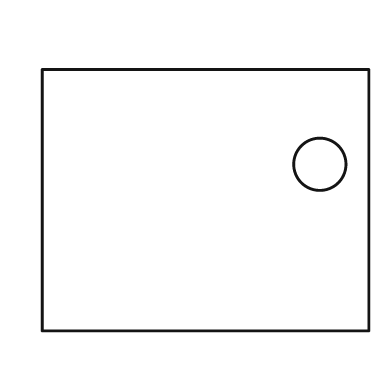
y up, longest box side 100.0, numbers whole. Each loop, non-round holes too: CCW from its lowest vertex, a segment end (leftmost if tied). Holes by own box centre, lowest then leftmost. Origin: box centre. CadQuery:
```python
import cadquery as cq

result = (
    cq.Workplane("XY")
    .moveTo(-50.0, -40.0)
    .lineTo(50.0, -40.0)
    .lineTo(50.0, 40.0)
    .lineTo(-50.0, 40.0)
    .close()
    .moveTo(35.0, 11.0)
    .circle(8.0)
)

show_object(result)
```